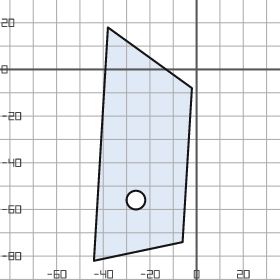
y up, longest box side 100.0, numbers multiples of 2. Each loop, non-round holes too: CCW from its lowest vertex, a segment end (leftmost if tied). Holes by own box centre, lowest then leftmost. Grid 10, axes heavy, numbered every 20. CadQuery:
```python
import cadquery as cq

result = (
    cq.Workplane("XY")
    .moveTo(-44.0, -82.0)
    .lineTo(-6.0, -74.0)
    .lineTo(-2.0, -8.0)
    .lineTo(-38.0, 18.0)
    .close()
    .moveTo(-26.0, -56.0)
    .circle(4.0)
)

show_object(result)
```